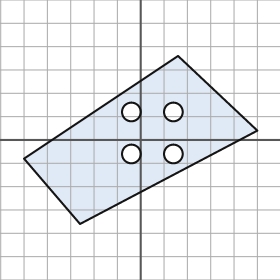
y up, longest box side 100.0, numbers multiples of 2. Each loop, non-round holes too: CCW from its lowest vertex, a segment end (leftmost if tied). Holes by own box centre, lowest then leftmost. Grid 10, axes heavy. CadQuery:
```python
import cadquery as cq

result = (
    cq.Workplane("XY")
    .moveTo(-26.0, -36.0)
    .lineTo(50.0, 4.0)
    .lineTo(16.0, 36.0)
    .lineTo(-50.0, -8.0)
    .close()
    .moveTo(-4.0, -6.0)
    .circle(4.0)
    .moveTo(14.0, -6.0)
    .circle(4.0)
    .moveTo(-4.0, 12.0)
    .circle(4.0)
    .moveTo(14.0, 12.0)
    .circle(4.0)
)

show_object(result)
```